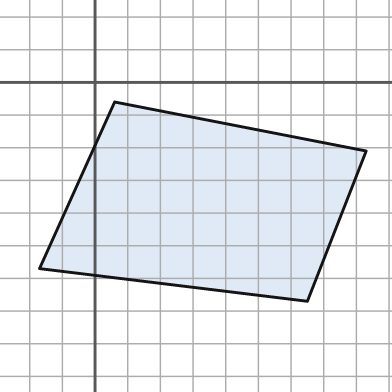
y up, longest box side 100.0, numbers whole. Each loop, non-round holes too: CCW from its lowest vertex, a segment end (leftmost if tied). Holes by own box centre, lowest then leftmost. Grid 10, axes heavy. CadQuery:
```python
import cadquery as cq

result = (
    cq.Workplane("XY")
    .moveTo(65.0, -67.0)
    .lineTo(83.0, -21.0)
    .lineTo(6.0, -6.0)
    .lineTo(-17.0, -57.0)
    .close()
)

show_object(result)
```